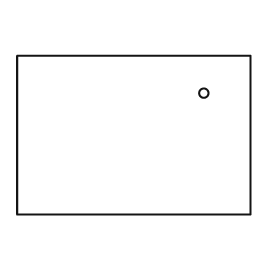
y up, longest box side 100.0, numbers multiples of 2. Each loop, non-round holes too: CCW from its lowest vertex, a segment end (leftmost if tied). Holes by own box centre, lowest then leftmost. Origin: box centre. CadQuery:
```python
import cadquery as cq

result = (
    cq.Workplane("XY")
    .moveTo(-50.0, -34.0)
    .lineTo(50.0, -34.0)
    .lineTo(50.0, 34.0)
    .lineTo(-50.0, 34.0)
    .close()
    .moveTo(30.0, 18.0)
    .circle(2.0)
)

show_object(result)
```